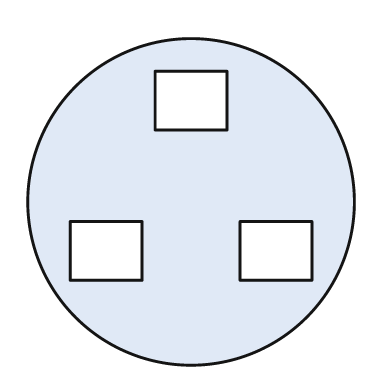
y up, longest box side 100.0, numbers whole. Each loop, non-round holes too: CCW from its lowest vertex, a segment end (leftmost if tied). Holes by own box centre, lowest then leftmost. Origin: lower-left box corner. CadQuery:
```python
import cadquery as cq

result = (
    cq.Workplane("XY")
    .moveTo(50.0, 50.0)
    .circle(50.0)
    .moveTo(13.0, 26.0)
    .lineTo(35.0, 26.0)
    .lineTo(35.0, 44.0)
    .lineTo(13.0, 44.0)
    .close()
    .moveTo(65.0, 26.0)
    .lineTo(87.0, 26.0)
    .lineTo(87.0, 44.0)
    .lineTo(65.0, 44.0)
    .close()
    .moveTo(39.0, 72.0)
    .lineTo(61.0, 72.0)
    .lineTo(61.0, 90.0)
    .lineTo(39.0, 90.0)
    .close()
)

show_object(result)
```